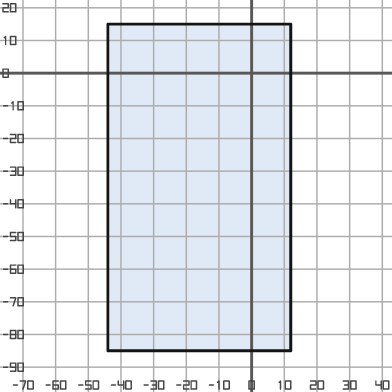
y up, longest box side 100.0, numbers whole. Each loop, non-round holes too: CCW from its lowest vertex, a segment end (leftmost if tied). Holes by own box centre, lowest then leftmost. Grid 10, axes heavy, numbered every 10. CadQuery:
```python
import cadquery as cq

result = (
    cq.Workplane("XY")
    .moveTo(-44.0, -85.0)
    .lineTo(12.0, -85.0)
    .lineTo(12.0, 15.0)
    .lineTo(-44.0, 15.0)
    .close()
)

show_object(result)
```